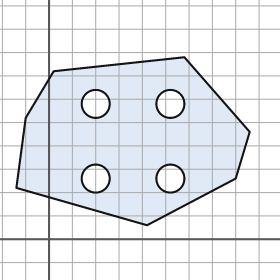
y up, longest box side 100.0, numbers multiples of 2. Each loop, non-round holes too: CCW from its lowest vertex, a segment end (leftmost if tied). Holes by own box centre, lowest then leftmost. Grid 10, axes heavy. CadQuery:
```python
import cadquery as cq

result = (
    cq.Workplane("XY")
    .moveTo(42.0, 6.0)
    .lineTo(80.0, 26.0)
    .lineTo(86.0, 46.0)
    .lineTo(58.0, 78.0)
    .lineTo(2.0, 72.0)
    .lineTo(-10.0, 52.0)
    .lineTo(-14.0, 22.0)
    .close()
    .moveTo(20.0, 26.0)
    .circle(6.0)
    .moveTo(52.0, 26.0)
    .circle(6.0)
    .moveTo(20.0, 58.0)
    .circle(6.0)
    .moveTo(52.0, 58.0)
    .circle(6.0)
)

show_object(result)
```